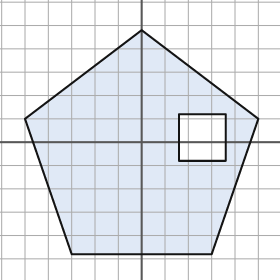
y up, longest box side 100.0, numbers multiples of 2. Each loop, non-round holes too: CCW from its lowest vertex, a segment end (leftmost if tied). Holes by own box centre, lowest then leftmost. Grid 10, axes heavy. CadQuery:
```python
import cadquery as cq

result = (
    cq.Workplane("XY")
    .moveTo(-30.0, -48.0)
    .lineTo(30.0, -48.0)
    .lineTo(50.0, 10.0)
    .lineTo(0.0, 48.0)
    .lineTo(-50.0, 10.0)
    .close()
    .moveTo(16.0, -8.0)
    .lineTo(36.0, -8.0)
    .lineTo(36.0, 12.0)
    .lineTo(16.0, 12.0)
    .close()
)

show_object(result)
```